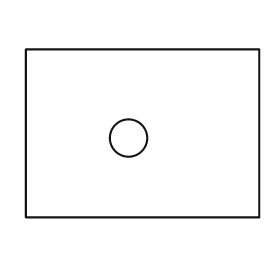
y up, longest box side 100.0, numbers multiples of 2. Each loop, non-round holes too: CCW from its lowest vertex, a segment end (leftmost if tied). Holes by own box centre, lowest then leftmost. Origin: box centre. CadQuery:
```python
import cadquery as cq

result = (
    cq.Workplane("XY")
    .moveTo(-50.0, -36.0)
    .lineTo(50.0, -36.0)
    .lineTo(50.0, 36.0)
    .lineTo(-50.0, 36.0)
    .close()
    .moveTo(-6.0, -2.0)
    .circle(8.0)
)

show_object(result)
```